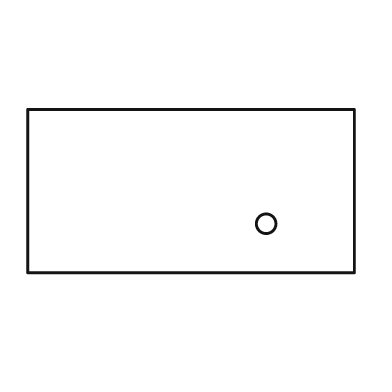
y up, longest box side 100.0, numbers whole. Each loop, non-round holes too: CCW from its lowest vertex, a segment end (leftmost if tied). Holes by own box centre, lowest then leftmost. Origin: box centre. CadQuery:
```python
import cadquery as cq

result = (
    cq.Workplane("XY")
    .moveTo(-50.0, -25.0)
    .lineTo(50.0, -25.0)
    .lineTo(50.0, 25.0)
    .lineTo(-50.0, 25.0)
    .close()
    .moveTo(23.0, -10.0)
    .circle(3.0)
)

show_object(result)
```